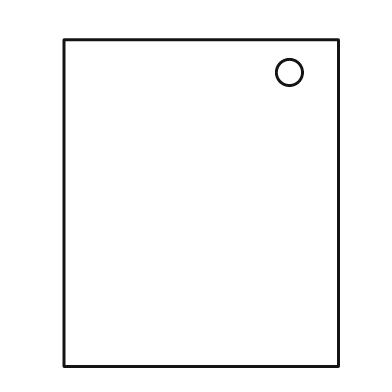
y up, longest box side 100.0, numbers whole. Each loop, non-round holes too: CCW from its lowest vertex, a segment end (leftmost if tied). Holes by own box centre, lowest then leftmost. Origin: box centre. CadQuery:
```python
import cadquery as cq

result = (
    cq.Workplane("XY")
    .moveTo(-42.0, -50.0)
    .lineTo(42.0, -50.0)
    .lineTo(42.0, 50.0)
    .lineTo(-42.0, 50.0)
    .close()
    .moveTo(27.0, 40.0)
    .circle(4.0)
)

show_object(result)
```